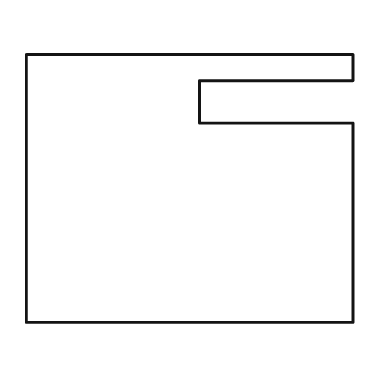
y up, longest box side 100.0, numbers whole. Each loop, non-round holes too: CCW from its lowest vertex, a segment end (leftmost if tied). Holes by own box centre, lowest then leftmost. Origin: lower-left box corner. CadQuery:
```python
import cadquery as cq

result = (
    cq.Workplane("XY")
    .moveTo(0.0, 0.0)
    .lineTo(100.0, 0.0)
    .lineTo(100.0, 61.0)
    .lineTo(53.0, 61.0)
    .lineTo(53.0, 74.0)
    .lineTo(100.0, 74.0)
    .lineTo(100.0, 82.0)
    .lineTo(0.0, 82.0)
    .close()
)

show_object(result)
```